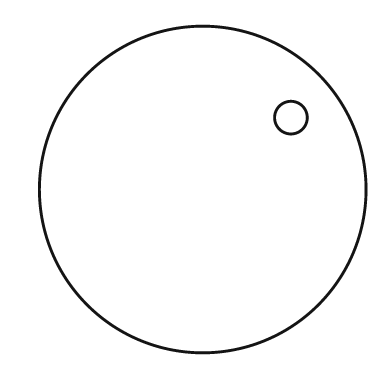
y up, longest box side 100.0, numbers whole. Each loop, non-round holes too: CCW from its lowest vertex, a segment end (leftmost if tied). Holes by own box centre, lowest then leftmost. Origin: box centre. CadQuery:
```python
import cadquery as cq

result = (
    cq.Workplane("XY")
    .moveTo(0.0, 0.0)
    .circle(50.0)
    .moveTo(27.0, 22.0)
    .circle(5.0)
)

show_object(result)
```